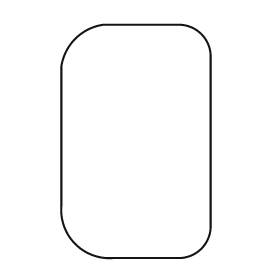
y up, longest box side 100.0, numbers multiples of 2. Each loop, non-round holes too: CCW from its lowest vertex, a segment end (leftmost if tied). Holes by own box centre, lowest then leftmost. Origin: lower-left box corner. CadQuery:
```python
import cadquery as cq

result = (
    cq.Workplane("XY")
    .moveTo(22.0, 0.0)
    .lineTo(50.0, 0.0)
    .threePointArc((60.0, 4.0), (64.0, 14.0))
    .lineTo(64.0, 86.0)
    .threePointArc((60.0, 96.0), (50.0, 100.0))
    .lineTo(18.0, 100.0)
    .threePointArc((6.0, 94.0), (0.0, 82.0))
    .lineTo(0.0, 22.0)
    .threePointArc((6.0, 6.0), (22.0, 0.0))
    .close()
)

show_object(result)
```